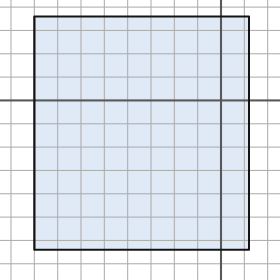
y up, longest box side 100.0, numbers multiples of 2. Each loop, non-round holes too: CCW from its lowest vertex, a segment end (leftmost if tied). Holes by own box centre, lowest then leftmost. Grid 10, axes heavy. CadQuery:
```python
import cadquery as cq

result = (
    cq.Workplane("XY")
    .moveTo(-80.0, -64.0)
    .lineTo(12.0, -64.0)
    .lineTo(12.0, 36.0)
    .lineTo(-80.0, 36.0)
    .close()
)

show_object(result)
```